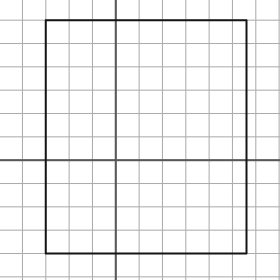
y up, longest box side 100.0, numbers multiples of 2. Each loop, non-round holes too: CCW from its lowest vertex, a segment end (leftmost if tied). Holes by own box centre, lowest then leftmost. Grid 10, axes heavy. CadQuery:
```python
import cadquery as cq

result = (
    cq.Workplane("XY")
    .moveTo(-30.0, -40.0)
    .lineTo(56.0, -40.0)
    .lineTo(56.0, 60.0)
    .lineTo(-30.0, 60.0)
    .close()
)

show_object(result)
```